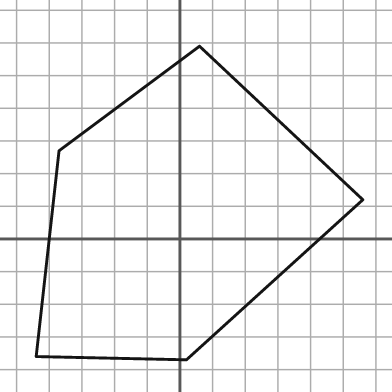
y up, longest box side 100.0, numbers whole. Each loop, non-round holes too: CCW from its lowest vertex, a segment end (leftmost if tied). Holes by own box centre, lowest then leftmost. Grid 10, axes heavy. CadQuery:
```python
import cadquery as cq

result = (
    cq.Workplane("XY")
    .moveTo(2.0, -37.0)
    .lineTo(56.0, 12.0)
    .lineTo(6.0, 59.0)
    .lineTo(-37.0, 27.0)
    .lineTo(-44.0, -36.0)
    .close()
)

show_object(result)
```